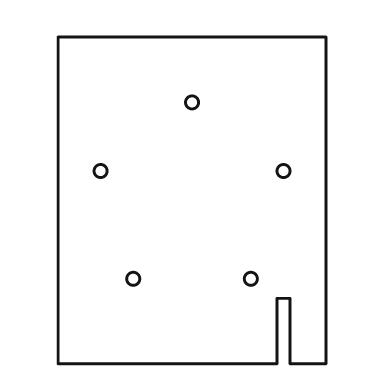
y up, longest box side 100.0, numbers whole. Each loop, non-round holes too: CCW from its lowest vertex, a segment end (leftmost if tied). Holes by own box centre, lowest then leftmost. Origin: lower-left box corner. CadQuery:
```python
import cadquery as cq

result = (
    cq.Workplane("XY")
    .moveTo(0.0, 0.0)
    .lineTo(67.0, 0.0)
    .lineTo(67.0, 20.0)
    .lineTo(71.0, 20.0)
    .lineTo(71.0, 0.0)
    .lineTo(82.0, 0.0)
    .lineTo(82.0, 100.0)
    .lineTo(0.0, 100.0)
    .close()
    .moveTo(23.0, 26.0)
    .circle(2.0)
    .moveTo(59.0, 26.0)
    .circle(2.0)
    .moveTo(13.0, 59.0)
    .circle(2.0)
    .moveTo(69.0, 59.0)
    .circle(2.0)
    .moveTo(41.0, 80.0)
    .circle(2.0)
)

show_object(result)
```